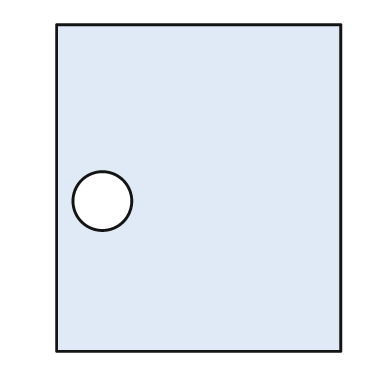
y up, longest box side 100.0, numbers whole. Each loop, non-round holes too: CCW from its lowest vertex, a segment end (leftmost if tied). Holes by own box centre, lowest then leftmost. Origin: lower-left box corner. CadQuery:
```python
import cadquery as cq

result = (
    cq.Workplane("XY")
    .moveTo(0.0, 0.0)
    .lineTo(87.0, 0.0)
    .lineTo(87.0, 100.0)
    .lineTo(0.0, 100.0)
    .close()
    .moveTo(14.0, 46.0)
    .circle(9.0)
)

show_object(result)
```